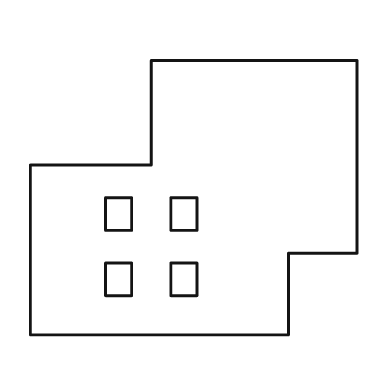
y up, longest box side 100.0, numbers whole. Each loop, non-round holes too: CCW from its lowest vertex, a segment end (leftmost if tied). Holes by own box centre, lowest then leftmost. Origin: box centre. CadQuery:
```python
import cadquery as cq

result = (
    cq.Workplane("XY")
    .moveTo(-50.0, -42.0)
    .lineTo(29.0, -42.0)
    .lineTo(29.0, -17.0)
    .lineTo(50.0, -17.0)
    .lineTo(50.0, 42.0)
    .lineTo(-13.0, 42.0)
    .lineTo(-13.0, 10.0)
    .lineTo(-50.0, 10.0)
    .close()
    .moveTo(-27.0, -30.0)
    .lineTo(-19.0, -30.0)
    .lineTo(-19.0, -20.0)
    .lineTo(-27.0, -20.0)
    .close()
    .moveTo(-7.0, -30.0)
    .lineTo(1.0, -30.0)
    .lineTo(1.0, -20.0)
    .lineTo(-7.0, -20.0)
    .close()
    .moveTo(-27.0, -10.0)
    .lineTo(-19.0, -10.0)
    .lineTo(-19.0, 0.0)
    .lineTo(-27.0, 0.0)
    .close()
    .moveTo(-7.0, -10.0)
    .lineTo(1.0, -10.0)
    .lineTo(1.0, 0.0)
    .lineTo(-7.0, 0.0)
    .close()
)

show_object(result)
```